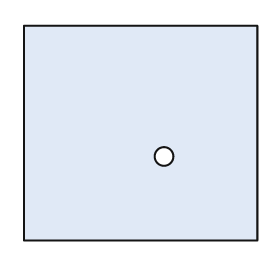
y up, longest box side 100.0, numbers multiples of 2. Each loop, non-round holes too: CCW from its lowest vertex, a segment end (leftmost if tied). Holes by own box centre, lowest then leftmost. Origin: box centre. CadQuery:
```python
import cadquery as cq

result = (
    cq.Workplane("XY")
    .moveTo(-50.0, -46.0)
    .lineTo(50.0, -46.0)
    .lineTo(50.0, 46.0)
    .lineTo(-50.0, 46.0)
    .close()
    .moveTo(10.0, -10.0)
    .circle(4.0)
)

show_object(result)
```